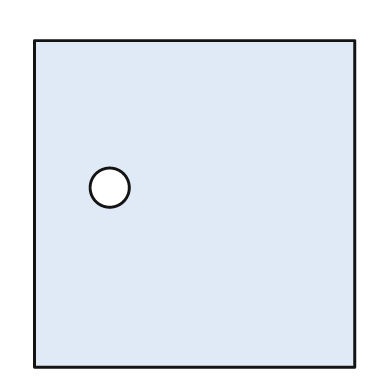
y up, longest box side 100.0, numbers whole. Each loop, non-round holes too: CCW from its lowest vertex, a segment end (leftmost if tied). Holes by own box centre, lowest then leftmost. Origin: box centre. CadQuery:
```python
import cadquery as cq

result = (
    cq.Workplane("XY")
    .moveTo(-49.0, -50.0)
    .lineTo(49.0, -50.0)
    .lineTo(49.0, 50.0)
    .lineTo(-49.0, 50.0)
    .close()
    .moveTo(-26.0, 5.0)
    .circle(6.0)
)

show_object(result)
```